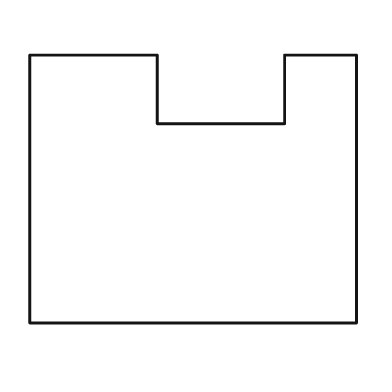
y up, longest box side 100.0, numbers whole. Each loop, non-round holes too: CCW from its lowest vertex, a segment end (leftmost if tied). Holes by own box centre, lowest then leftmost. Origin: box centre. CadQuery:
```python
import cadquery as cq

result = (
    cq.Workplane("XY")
    .moveTo(-50.0, -41.0)
    .lineTo(50.0, -41.0)
    .lineTo(50.0, 41.0)
    .lineTo(28.0, 41.0)
    .lineTo(28.0, 20.0)
    .lineTo(-11.0, 20.0)
    .lineTo(-11.0, 41.0)
    .lineTo(-50.0, 41.0)
    .close()
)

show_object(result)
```